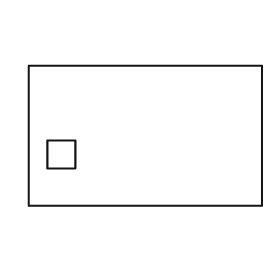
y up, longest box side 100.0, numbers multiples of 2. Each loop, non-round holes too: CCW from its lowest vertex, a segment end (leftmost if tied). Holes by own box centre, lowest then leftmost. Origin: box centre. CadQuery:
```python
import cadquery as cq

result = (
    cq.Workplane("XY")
    .moveTo(-50.0, -30.0)
    .lineTo(50.0, -30.0)
    .lineTo(50.0, 30.0)
    .lineTo(-50.0, 30.0)
    .close()
    .moveTo(-42.0, -14.0)
    .lineTo(-30.0, -14.0)
    .lineTo(-30.0, -2.0)
    .lineTo(-42.0, -2.0)
    .close()
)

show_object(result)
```